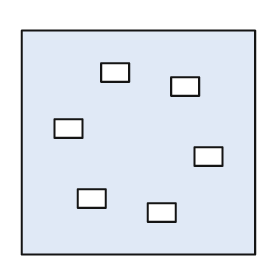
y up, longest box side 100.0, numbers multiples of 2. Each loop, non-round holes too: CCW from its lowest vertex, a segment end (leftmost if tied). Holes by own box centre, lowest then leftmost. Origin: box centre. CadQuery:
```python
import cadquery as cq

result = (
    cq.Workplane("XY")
    .moveTo(-50.0, -48.0)
    .lineTo(50.0, -48.0)
    .lineTo(50.0, 48.0)
    .lineTo(-50.0, 48.0)
    .close()
    .moveTo(4.0, -34.0)
    .lineTo(16.0, -34.0)
    .lineTo(16.0, -26.0)
    .lineTo(4.0, -26.0)
    .close()
    .moveTo(-26.0, -28.0)
    .lineTo(-14.0, -28.0)
    .lineTo(-14.0, -20.0)
    .lineTo(-26.0, -20.0)
    .close()
    .moveTo(24.0, -10.0)
    .lineTo(36.0, -10.0)
    .lineTo(36.0, -2.0)
    .lineTo(24.0, -2.0)
    .close()
    .moveTo(-36.0, 2.0)
    .lineTo(-24.0, 2.0)
    .lineTo(-24.0, 10.0)
    .lineTo(-36.0, 10.0)
    .close()
    .moveTo(14.0, 20.0)
    .lineTo(26.0, 20.0)
    .lineTo(26.0, 28.0)
    .lineTo(14.0, 28.0)
    .close()
    .moveTo(-16.0, 26.0)
    .lineTo(-4.0, 26.0)
    .lineTo(-4.0, 34.0)
    .lineTo(-16.0, 34.0)
    .close()
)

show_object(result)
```